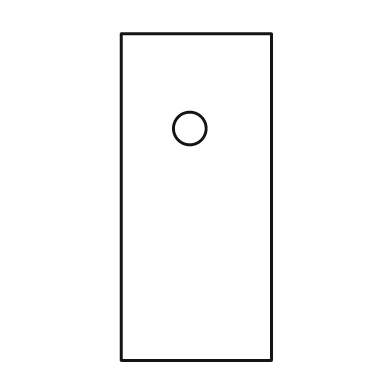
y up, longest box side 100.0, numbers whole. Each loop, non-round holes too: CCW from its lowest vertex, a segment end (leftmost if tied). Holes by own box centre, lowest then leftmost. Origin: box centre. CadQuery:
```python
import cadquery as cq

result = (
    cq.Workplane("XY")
    .moveTo(-23.0, -50.0)
    .lineTo(23.0, -50.0)
    .lineTo(23.0, 50.0)
    .lineTo(-23.0, 50.0)
    .close()
    .moveTo(-2.0, 21.0)
    .circle(5.0)
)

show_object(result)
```